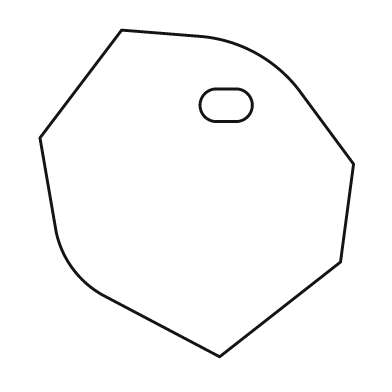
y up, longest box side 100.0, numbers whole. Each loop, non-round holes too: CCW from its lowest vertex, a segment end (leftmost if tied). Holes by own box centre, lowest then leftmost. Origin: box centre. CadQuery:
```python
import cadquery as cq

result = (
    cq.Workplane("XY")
    .moveTo(7.0, -50.0)
    .lineTo(44.0, -21.0)
    .lineTo(48.0, 9.0)
    .lineTo(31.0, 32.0)
    .threePointArc((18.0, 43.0), (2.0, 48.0))
    .lineTo(-23.0, 50.0)
    .lineTo(-48.0, 17.0)
    .lineTo(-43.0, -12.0)
    .threePointArc((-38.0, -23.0), (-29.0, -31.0))
    .close()
    .moveTo(6.0, 22.0)
    .lineTo(12.0, 22.0)
    .threePointArc((17.0, 27.0), (12.0, 32.0))
    .lineTo(6.0, 32.0)
    .threePointArc((1.0, 27.0), (6.0, 22.0))
    .close()
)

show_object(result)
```